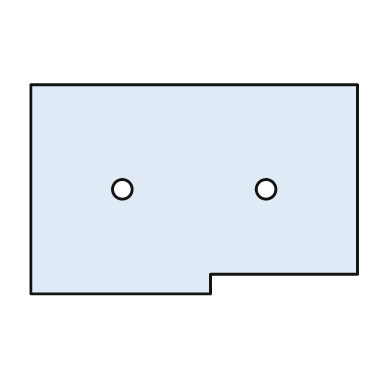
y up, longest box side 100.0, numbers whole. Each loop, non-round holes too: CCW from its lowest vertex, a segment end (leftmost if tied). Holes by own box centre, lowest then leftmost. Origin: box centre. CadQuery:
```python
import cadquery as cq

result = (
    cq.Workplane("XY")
    .moveTo(-50.0, -32.0)
    .lineTo(5.0, -32.0)
    .lineTo(5.0, -26.0)
    .lineTo(50.0, -26.0)
    .lineTo(50.0, 32.0)
    .lineTo(-50.0, 32.0)
    .close()
    .moveTo(-22.0, 0.0)
    .circle(3.0)
    .moveTo(22.0, 0.0)
    .circle(3.0)
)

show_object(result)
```